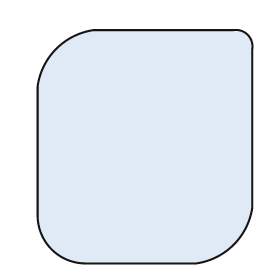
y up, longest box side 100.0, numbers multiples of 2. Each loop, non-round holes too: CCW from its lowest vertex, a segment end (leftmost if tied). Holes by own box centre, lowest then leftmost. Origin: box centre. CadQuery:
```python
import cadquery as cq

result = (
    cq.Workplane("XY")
    .moveTo(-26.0, -50.0)
    .lineTo(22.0, -50.0)
    .threePointArc((38.0, -42.0), (46.0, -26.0))
    .lineTo(46.0, 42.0)
    .threePointArc((44.0, 48.0), (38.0, 50.0))
    .lineTo(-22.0, 50.0)
    .threePointArc((-38.0, 42.0), (-46.0, 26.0))
    .lineTo(-46.0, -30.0)
    .threePointArc((-40.0, -44.0), (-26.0, -50.0))
    .close()
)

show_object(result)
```